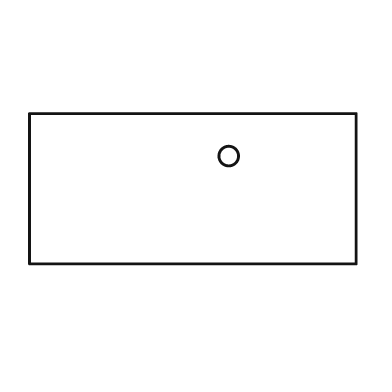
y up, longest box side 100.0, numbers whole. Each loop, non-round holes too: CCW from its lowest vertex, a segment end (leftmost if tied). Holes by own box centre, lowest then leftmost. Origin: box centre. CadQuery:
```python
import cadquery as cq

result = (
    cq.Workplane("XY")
    .moveTo(-50.0, -23.0)
    .lineTo(50.0, -23.0)
    .lineTo(50.0, 23.0)
    .lineTo(-50.0, 23.0)
    .close()
    .moveTo(11.0, 10.0)
    .circle(3.0)
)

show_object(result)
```